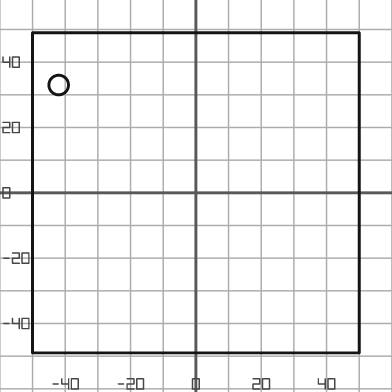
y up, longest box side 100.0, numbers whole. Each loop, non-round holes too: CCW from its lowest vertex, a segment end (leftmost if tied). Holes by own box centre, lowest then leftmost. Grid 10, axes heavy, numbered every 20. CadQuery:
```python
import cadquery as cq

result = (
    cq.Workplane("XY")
    .moveTo(-50.0, -49.0)
    .lineTo(50.0, -49.0)
    .lineTo(50.0, 49.0)
    .lineTo(-50.0, 49.0)
    .close()
    .moveTo(-42.0, 33.0)
    .circle(3.0)
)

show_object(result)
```